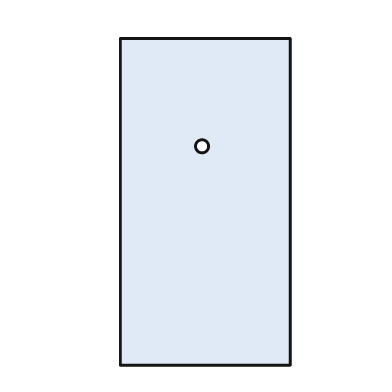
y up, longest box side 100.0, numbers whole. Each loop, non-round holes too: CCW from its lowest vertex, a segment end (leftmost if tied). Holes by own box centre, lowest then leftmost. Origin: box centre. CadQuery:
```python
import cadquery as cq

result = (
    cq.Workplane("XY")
    .moveTo(-26.0, -50.0)
    .lineTo(26.0, -50.0)
    .lineTo(26.0, 50.0)
    .lineTo(-26.0, 50.0)
    .close()
    .moveTo(-1.0, 17.0)
    .circle(2.0)
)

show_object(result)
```